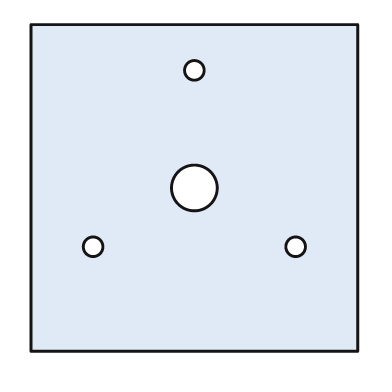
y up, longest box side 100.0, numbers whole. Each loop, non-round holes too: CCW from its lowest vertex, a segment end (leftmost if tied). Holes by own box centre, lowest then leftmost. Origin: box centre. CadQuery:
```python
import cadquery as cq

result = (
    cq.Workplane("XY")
    .moveTo(-50.0, -50.0)
    .lineTo(50.0, -50.0)
    .lineTo(50.0, 50.0)
    .lineTo(-50.0, 50.0)
    .close()
    .moveTo(-31.0, -18.0)
    .circle(3.0)
    .moveTo(31.0, -18.0)
    .circle(3.0)
    .moveTo(0.0, 0.0)
    .circle(7.0)
    .moveTo(0.0, 36.0)
    .circle(3.0)
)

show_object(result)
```